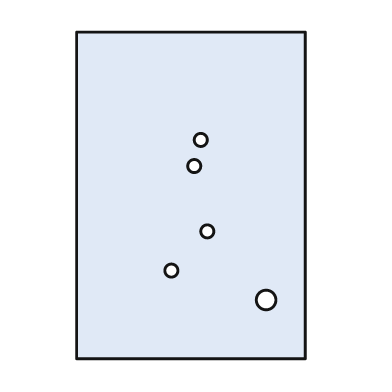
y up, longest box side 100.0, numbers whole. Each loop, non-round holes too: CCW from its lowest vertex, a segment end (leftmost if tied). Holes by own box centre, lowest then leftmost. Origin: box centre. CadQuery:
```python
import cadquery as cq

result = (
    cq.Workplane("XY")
    .moveTo(-35.0, -50.0)
    .lineTo(35.0, -50.0)
    .lineTo(35.0, 50.0)
    .lineTo(-35.0, 50.0)
    .close()
    .moveTo(23.0, -32.0)
    .circle(3.0)
    .moveTo(-6.0, -23.0)
    .circle(2.0)
    .moveTo(5.0, -11.0)
    .circle(2.0)
    .moveTo(1.0, 9.0)
    .circle(2.0)
    .moveTo(3.0, 17.0)
    .circle(2.0)
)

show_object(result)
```